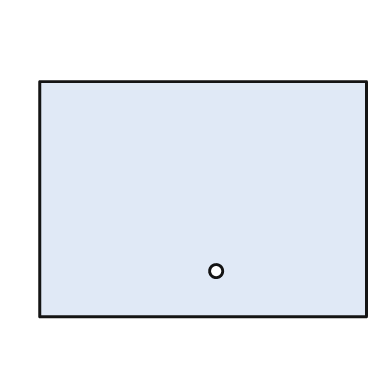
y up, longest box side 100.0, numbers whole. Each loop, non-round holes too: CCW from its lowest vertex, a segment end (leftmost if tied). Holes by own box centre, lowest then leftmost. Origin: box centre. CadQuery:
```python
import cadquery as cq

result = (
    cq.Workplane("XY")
    .moveTo(-50.0, -36.0)
    .lineTo(50.0, -36.0)
    .lineTo(50.0, 36.0)
    .lineTo(-50.0, 36.0)
    .close()
    .moveTo(4.0, -22.0)
    .circle(2.0)
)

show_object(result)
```